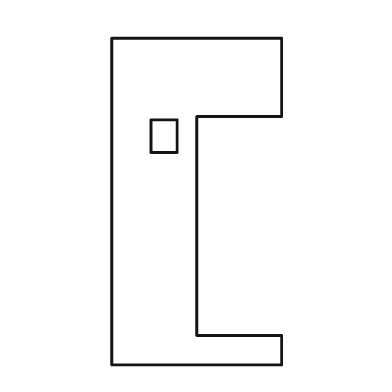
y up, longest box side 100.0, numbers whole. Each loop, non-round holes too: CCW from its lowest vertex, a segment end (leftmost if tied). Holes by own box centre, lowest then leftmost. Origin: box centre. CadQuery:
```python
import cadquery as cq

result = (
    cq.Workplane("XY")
    .moveTo(-26.0, -50.0)
    .lineTo(26.0, -50.0)
    .lineTo(26.0, -41.0)
    .lineTo(0.0, -41.0)
    .lineTo(0.0, 26.0)
    .lineTo(26.0, 26.0)
    .lineTo(26.0, 50.0)
    .lineTo(-26.0, 50.0)
    .close()
    .moveTo(-14.0, 15.0)
    .lineTo(-6.0, 15.0)
    .lineTo(-6.0, 25.0)
    .lineTo(-14.0, 25.0)
    .close()
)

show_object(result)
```